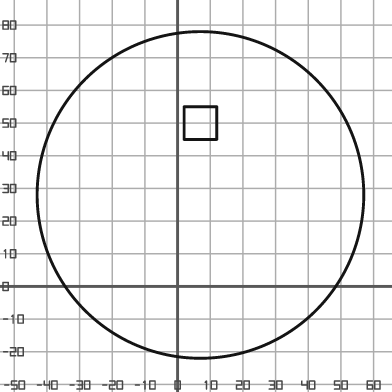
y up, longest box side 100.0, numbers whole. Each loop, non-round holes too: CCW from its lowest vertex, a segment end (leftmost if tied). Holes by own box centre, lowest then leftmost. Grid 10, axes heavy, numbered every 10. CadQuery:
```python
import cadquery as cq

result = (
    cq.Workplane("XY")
    .moveTo(7.0, 28.0)
    .circle(50.0)
    .moveTo(2.0, 45.0)
    .lineTo(12.0, 45.0)
    .lineTo(12.0, 55.0)
    .lineTo(2.0, 55.0)
    .close()
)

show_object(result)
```